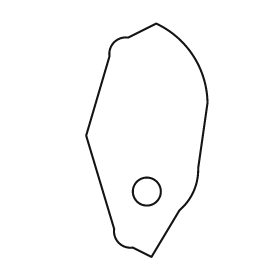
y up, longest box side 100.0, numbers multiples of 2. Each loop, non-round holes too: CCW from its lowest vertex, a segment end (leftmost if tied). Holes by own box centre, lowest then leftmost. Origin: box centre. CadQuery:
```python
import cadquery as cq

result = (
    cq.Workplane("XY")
    .moveTo(2.0, -50.0)
    .lineTo(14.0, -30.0)
    .threePointArc((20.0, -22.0), (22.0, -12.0))
    .lineTo(26.0, 16.0)
    .threePointArc((20.0, 36.0), (4.0, 50.0))
    .lineTo(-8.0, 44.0)
    .threePointArc((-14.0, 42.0), (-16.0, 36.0))
    .lineTo(-26.0, 2.0)
    .lineTo(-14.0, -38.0)
    .threePointArc((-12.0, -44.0), (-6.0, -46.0))
    .close()
    .moveTo(0.0, -22.0)
    .circle(6.0)
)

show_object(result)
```